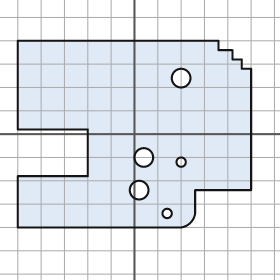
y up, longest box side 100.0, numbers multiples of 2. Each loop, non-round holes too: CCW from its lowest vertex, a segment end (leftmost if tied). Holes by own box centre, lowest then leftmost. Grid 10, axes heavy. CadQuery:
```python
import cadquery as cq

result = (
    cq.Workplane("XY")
    .moveTo(-50.0, -40.0)
    .lineTo(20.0, -40.0)
    .threePointArc((24.0, -38.0), (26.0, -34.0))
    .lineTo(26.0, -24.0)
    .lineTo(50.0, -24.0)
    .lineTo(50.0, 28.0)
    .lineTo(46.0, 28.0)
    .lineTo(46.0, 32.0)
    .lineTo(42.0, 32.0)
    .lineTo(42.0, 36.0)
    .lineTo(36.0, 36.0)
    .lineTo(36.0, 40.0)
    .lineTo(-50.0, 40.0)
    .lineTo(-50.0, 2.0)
    .lineTo(-20.0, 2.0)
    .lineTo(-20.0, -18.0)
    .lineTo(-50.0, -18.0)
    .close()
    .moveTo(14.0, -34.0)
    .circle(2.0)
    .moveTo(2.0, -24.0)
    .circle(4.0)
    .moveTo(20.0, -12.0)
    .circle(2.0)
    .moveTo(4.0, -10.0)
    .circle(4.0)
    .moveTo(20.0, 24.0)
    .circle(4.0)
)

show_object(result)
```